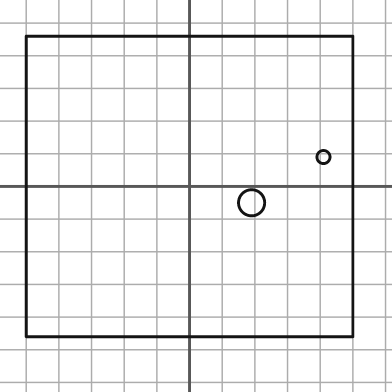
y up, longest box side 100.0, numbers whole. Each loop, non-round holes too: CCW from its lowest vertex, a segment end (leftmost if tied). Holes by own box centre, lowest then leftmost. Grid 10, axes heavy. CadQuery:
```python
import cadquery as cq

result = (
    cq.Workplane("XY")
    .moveTo(-50.0, -46.0)
    .lineTo(50.0, -46.0)
    .lineTo(50.0, 46.0)
    .lineTo(-50.0, 46.0)
    .close()
    .moveTo(19.0, -5.0)
    .circle(4.0)
    .moveTo(41.0, 9.0)
    .circle(2.0)
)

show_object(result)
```